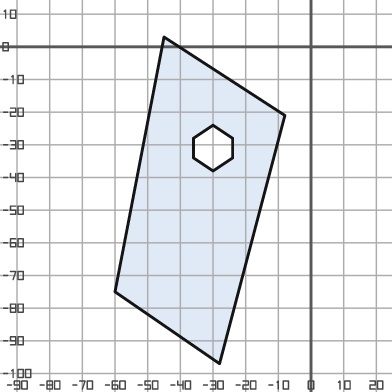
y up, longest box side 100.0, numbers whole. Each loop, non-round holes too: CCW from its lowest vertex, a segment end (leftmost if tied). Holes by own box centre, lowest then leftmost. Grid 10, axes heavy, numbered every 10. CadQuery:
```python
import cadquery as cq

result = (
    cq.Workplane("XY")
    .moveTo(-28.0, -97.0)
    .lineTo(-8.0, -21.0)
    .lineTo(-45.0, 3.0)
    .lineTo(-60.0, -75.0)
    .close()
    .moveTo(-30.0, -38.0)
    .lineTo(-24.0, -34.0)
    .lineTo(-24.0, -28.0)
    .lineTo(-30.0, -24.0)
    .lineTo(-36.0, -28.0)
    .lineTo(-36.0, -34.0)
    .close()
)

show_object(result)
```